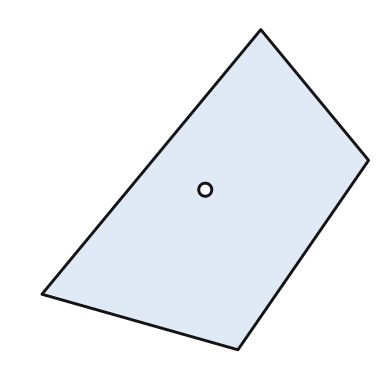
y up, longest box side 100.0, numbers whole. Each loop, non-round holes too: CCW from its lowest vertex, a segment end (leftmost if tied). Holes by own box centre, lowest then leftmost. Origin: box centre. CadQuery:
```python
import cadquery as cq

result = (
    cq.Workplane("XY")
    .moveTo(10.0, -49.0)
    .lineTo(50.0, 9.0)
    .lineTo(17.0, 49.0)
    .lineTo(-50.0, -32.0)
    .close()
    .moveTo(0.0, 0.0)
    .circle(2.0)
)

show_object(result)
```